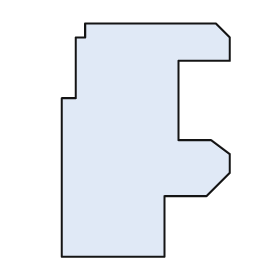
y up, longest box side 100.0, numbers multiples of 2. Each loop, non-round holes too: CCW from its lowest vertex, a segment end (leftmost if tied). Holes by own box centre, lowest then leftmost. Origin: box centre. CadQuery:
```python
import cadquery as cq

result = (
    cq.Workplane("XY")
    .moveTo(-36.0, -50.0)
    .lineTo(8.0, -50.0)
    .lineTo(8.0, -24.0)
    .lineTo(26.0, -24.0)
    .lineTo(36.0, -14.0)
    .lineTo(36.0, -6.0)
    .lineTo(28.0, 0.0)
    .lineTo(14.0, 0.0)
    .lineTo(14.0, 34.0)
    .lineTo(36.0, 34.0)
    .lineTo(36.0, 44.0)
    .lineTo(30.0, 50.0)
    .lineTo(-26.0, 50.0)
    .lineTo(-26.0, 44.0)
    .lineTo(-30.0, 44.0)
    .lineTo(-30.0, 18.0)
    .lineTo(-36.0, 18.0)
    .close()
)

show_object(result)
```